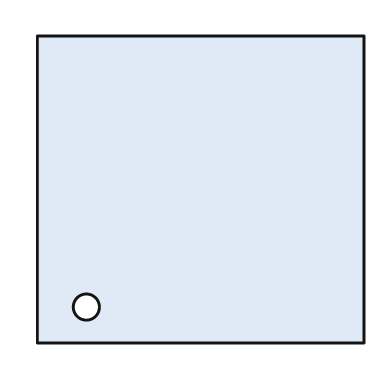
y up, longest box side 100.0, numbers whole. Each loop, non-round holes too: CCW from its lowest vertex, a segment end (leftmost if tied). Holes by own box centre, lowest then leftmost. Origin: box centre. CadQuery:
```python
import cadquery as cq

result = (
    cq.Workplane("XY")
    .moveTo(-50.0, -47.0)
    .lineTo(50.0, -47.0)
    .lineTo(50.0, 47.0)
    .lineTo(-50.0, 47.0)
    .close()
    .moveTo(-35.0, -36.0)
    .circle(4.0)
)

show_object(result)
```